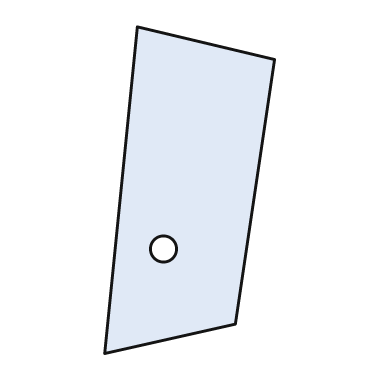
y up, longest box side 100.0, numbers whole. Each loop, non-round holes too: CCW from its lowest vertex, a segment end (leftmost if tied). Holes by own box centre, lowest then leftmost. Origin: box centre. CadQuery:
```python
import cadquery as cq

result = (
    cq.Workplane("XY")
    .moveTo(-26.0, -50.0)
    .lineTo(14.0, -41.0)
    .lineTo(26.0, 40.0)
    .lineTo(-16.0, 50.0)
    .close()
    .moveTo(-8.0, -18.0)
    .circle(4.0)
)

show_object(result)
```